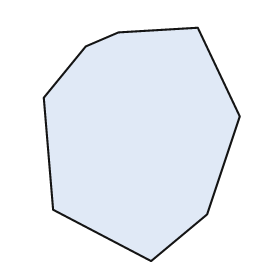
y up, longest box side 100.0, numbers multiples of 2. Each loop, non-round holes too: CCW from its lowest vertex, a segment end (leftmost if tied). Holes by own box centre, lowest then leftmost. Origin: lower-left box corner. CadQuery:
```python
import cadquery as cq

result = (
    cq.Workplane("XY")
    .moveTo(46.0, 0.0)
    .lineTo(70.0, 20.0)
    .lineTo(84.0, 62.0)
    .lineTo(66.0, 100.0)
    .lineTo(32.0, 98.0)
    .lineTo(18.0, 92.0)
    .lineTo(0.0, 70.0)
    .lineTo(4.0, 22.0)
    .close()
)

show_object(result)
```